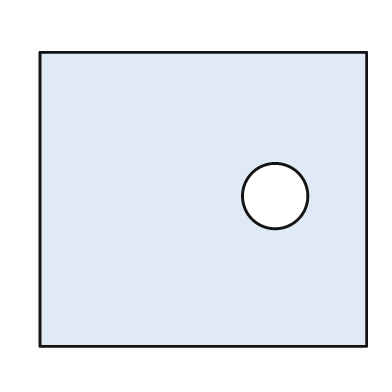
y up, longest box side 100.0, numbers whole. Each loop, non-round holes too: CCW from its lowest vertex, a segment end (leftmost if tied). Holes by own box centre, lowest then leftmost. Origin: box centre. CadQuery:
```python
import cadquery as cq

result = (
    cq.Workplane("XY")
    .moveTo(-50.0, -45.0)
    .lineTo(50.0, -45.0)
    .lineTo(50.0, 45.0)
    .lineTo(-50.0, 45.0)
    .close()
    .moveTo(22.0, 1.0)
    .circle(10.0)
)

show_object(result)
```